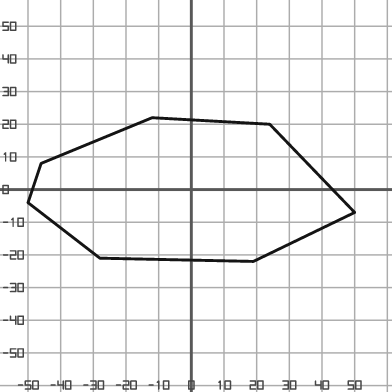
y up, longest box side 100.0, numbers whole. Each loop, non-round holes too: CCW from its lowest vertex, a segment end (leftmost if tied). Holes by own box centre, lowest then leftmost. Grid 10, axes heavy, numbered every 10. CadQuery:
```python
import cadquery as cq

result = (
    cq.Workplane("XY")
    .moveTo(19.0, -22.0)
    .lineTo(50.0, -7.0)
    .lineTo(24.0, 20.0)
    .lineTo(-12.0, 22.0)
    .lineTo(-46.0, 8.0)
    .lineTo(-50.0, -4.0)
    .lineTo(-28.0, -21.0)
    .close()
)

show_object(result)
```